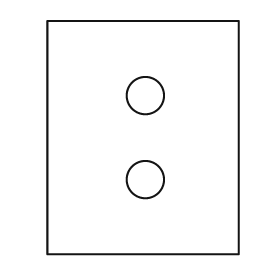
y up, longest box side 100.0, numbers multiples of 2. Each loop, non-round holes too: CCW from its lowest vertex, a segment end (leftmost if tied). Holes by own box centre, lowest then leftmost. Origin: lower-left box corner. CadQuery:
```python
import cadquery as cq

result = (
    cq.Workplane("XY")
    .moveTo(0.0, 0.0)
    .lineTo(82.0, 0.0)
    .lineTo(82.0, 100.0)
    .lineTo(0.0, 100.0)
    .close()
    .moveTo(42.0, 32.0)
    .circle(8.0)
    .moveTo(42.0, 68.0)
    .circle(8.0)
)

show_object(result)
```